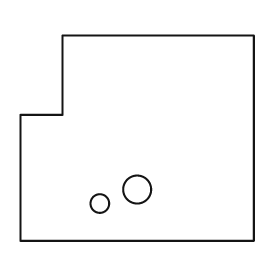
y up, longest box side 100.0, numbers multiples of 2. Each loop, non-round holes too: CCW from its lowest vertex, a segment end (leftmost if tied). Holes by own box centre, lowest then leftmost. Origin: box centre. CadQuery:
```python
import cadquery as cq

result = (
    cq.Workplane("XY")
    .moveTo(-50.0, -44.0)
    .lineTo(50.0, -44.0)
    .lineTo(50.0, 44.0)
    .lineTo(-32.0, 44.0)
    .lineTo(-32.0, 10.0)
    .lineTo(-50.0, 10.0)
    .close()
    .moveTo(-16.0, -28.0)
    .circle(4.0)
    .moveTo(0.0, -22.0)
    .circle(6.0)
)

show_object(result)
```